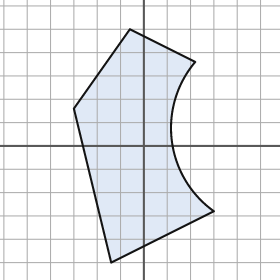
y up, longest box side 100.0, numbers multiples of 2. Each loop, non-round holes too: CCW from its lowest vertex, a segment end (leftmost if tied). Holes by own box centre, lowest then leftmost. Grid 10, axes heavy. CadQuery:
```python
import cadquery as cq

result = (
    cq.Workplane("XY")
    .moveTo(-14.0, -50.0)
    .lineTo(30.0, -28.0)
    .threePointArc((12.0, 2.0), (22.0, 36.0))
    .lineTo(-6.0, 50.0)
    .lineTo(-30.0, 16.0)
    .close()
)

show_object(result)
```